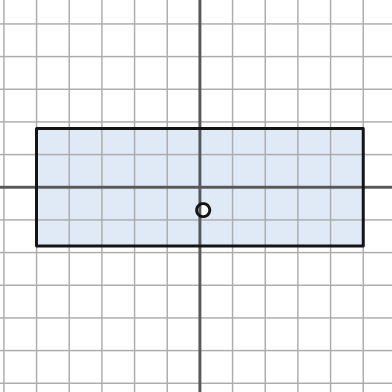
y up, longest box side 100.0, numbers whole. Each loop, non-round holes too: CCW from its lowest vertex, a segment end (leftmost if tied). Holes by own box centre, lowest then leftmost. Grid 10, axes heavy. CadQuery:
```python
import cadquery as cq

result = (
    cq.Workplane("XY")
    .moveTo(-50.0, -18.0)
    .lineTo(50.0, -18.0)
    .lineTo(50.0, 18.0)
    .lineTo(-50.0, 18.0)
    .close()
    .moveTo(1.0, -7.0)
    .circle(2.0)
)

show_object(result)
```